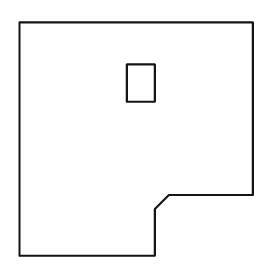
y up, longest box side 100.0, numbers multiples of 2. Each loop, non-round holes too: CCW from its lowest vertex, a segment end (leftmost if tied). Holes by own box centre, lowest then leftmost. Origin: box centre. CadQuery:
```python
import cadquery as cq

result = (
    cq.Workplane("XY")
    .moveTo(-50.0, -50.0)
    .lineTo(8.0, -50.0)
    .lineTo(8.0, -30.0)
    .lineTo(14.0, -24.0)
    .lineTo(50.0, -24.0)
    .lineTo(50.0, 50.0)
    .lineTo(-50.0, 50.0)
    .close()
    .moveTo(-4.0, 16.0)
    .lineTo(8.0, 16.0)
    .lineTo(8.0, 32.0)
    .lineTo(-4.0, 32.0)
    .close()
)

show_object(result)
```